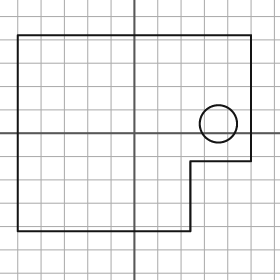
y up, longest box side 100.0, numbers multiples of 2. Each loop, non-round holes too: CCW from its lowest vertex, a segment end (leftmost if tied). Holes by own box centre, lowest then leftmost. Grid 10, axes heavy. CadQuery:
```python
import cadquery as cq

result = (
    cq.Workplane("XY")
    .moveTo(-50.0, -42.0)
    .lineTo(24.0, -42.0)
    .lineTo(24.0, -12.0)
    .lineTo(50.0, -12.0)
    .lineTo(50.0, 42.0)
    .lineTo(-50.0, 42.0)
    .close()
    .moveTo(36.0, 4.0)
    .circle(8.0)
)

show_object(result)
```